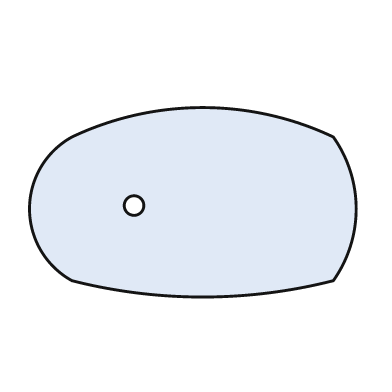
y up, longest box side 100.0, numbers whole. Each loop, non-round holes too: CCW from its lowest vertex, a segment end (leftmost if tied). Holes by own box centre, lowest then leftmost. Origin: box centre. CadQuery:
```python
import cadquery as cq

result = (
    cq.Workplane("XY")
    .moveTo(-37.0, -24.0)
    .threePointArc((3.0, -29.0), (43.0, -24.0))
    .threePointArc((50.0, -2.0), (43.0, 20.0))
    .threePointArc((3.0, 29.0), (-37.0, 20.0))
    .threePointArc((-50.0, -2.0), (-37.0, -24.0))
    .close()
    .moveTo(-18.0, -1.0)
    .circle(3.0)
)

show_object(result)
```